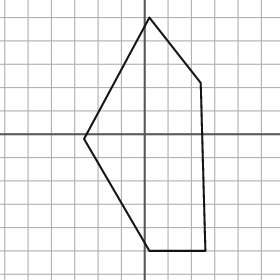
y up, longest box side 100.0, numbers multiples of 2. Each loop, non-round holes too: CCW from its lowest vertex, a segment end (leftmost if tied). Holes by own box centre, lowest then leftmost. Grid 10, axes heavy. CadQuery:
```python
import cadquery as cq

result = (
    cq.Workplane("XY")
    .moveTo(2.0, -50.0)
    .lineTo(26.0, -50.0)
    .lineTo(24.0, 22.0)
    .lineTo(2.0, 50.0)
    .lineTo(-26.0, -2.0)
    .close()
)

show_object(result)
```